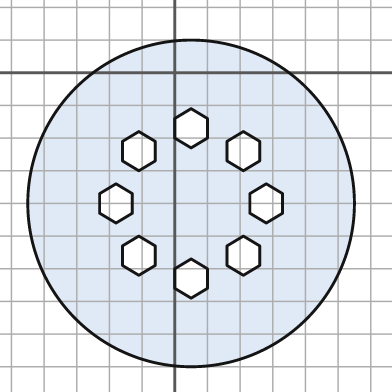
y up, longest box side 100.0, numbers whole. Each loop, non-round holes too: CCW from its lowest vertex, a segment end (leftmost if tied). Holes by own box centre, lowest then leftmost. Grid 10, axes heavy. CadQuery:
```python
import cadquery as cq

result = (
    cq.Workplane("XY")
    .moveTo(5.0, -40.0)
    .circle(50.0)
    .moveTo(5.0, -69.0)
    .lineTo(10.0, -66.0)
    .lineTo(10.0, -60.0)
    .lineTo(5.0, -57.0)
    .lineTo(0.0, -60.0)
    .lineTo(0.0, -66.0)
    .close()
    .moveTo(-11.0, -62.0)
    .lineTo(-6.0, -59.0)
    .lineTo(-6.0, -53.0)
    .lineTo(-11.0, -50.0)
    .lineTo(-16.0, -53.0)
    .lineTo(-16.0, -59.0)
    .close()
    .moveTo(21.0, -62.0)
    .lineTo(26.0, -59.0)
    .lineTo(26.0, -53.0)
    .lineTo(21.0, -50.0)
    .lineTo(16.0, -53.0)
    .lineTo(16.0, -59.0)
    .close()
    .moveTo(-18.0, -46.0)
    .lineTo(-13.0, -43.0)
    .lineTo(-13.0, -37.0)
    .lineTo(-18.0, -34.0)
    .lineTo(-23.0, -37.0)
    .lineTo(-23.0, -43.0)
    .close()
    .moveTo(28.0, -46.0)
    .lineTo(33.0, -43.0)
    .lineTo(33.0, -37.0)
    .lineTo(28.0, -34.0)
    .lineTo(23.0, -37.0)
    .lineTo(23.0, -43.0)
    .close()
    .moveTo(-11.0, -30.0)
    .lineTo(-6.0, -27.0)
    .lineTo(-6.0, -21.0)
    .lineTo(-11.0, -18.0)
    .lineTo(-16.0, -21.0)
    .lineTo(-16.0, -27.0)
    .close()
    .moveTo(21.0, -30.0)
    .lineTo(26.0, -27.0)
    .lineTo(26.0, -21.0)
    .lineTo(21.0, -18.0)
    .lineTo(16.0, -21.0)
    .lineTo(16.0, -27.0)
    .close()
    .moveTo(5.0, -23.0)
    .lineTo(10.0, -20.0)
    .lineTo(10.0, -14.0)
    .lineTo(5.0, -11.0)
    .lineTo(0.0, -14.0)
    .lineTo(0.0, -20.0)
    .close()
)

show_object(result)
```